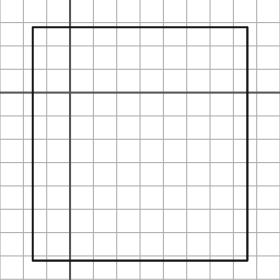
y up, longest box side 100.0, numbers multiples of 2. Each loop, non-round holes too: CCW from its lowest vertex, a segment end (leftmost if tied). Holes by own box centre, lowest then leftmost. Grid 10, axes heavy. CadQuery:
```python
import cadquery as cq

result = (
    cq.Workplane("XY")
    .moveTo(-16.0, -72.0)
    .lineTo(76.0, -72.0)
    .lineTo(76.0, 28.0)
    .lineTo(-16.0, 28.0)
    .close()
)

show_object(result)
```